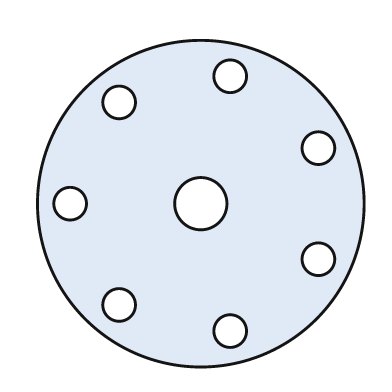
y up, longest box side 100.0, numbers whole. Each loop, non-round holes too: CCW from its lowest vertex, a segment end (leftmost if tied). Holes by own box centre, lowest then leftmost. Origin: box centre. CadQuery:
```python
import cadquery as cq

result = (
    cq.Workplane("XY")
    .moveTo(0.0, 0.0)
    .circle(50.0)
    .moveTo(9.0, -39.0)
    .circle(5.0)
    .moveTo(-25.0, -31.0)
    .circle(5.0)
    .moveTo(36.0, -17.0)
    .circle(5.0)
    .moveTo(-40.0, 0.0)
    .circle(5.0)
    .moveTo(0.0, 0.0)
    .circle(8.0)
    .moveTo(36.0, 17.0)
    .circle(5.0)
    .moveTo(-25.0, 31.0)
    .circle(5.0)
    .moveTo(9.0, 39.0)
    .circle(5.0)
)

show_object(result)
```